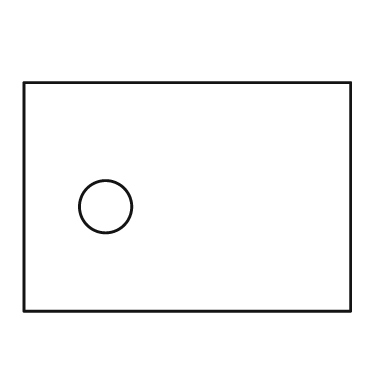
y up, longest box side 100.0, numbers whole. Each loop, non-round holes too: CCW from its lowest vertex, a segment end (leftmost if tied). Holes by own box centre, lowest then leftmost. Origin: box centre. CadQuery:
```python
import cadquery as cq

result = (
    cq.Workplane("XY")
    .moveTo(-50.0, -35.0)
    .lineTo(50.0, -35.0)
    .lineTo(50.0, 35.0)
    .lineTo(-50.0, 35.0)
    .close()
    .moveTo(-25.0, -3.0)
    .circle(8.0)
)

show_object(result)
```